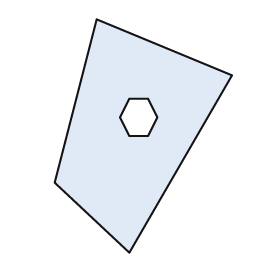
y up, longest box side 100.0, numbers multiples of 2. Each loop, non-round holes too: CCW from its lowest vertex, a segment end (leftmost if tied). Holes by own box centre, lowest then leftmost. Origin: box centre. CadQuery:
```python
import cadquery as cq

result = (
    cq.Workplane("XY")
    .moveTo(-6.0, -50.0)
    .lineTo(38.0, 26.0)
    .lineTo(-20.0, 50.0)
    .lineTo(-38.0, -20.0)
    .close()
    .moveTo(-6.0, 0.0)
    .lineTo(2.0, 0.0)
    .lineTo(6.0, 8.0)
    .lineTo(2.0, 16.0)
    .lineTo(-6.0, 16.0)
    .lineTo(-10.0, 8.0)
    .close()
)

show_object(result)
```